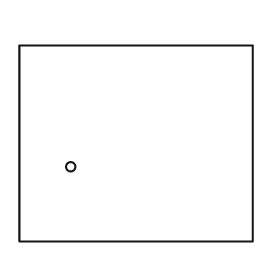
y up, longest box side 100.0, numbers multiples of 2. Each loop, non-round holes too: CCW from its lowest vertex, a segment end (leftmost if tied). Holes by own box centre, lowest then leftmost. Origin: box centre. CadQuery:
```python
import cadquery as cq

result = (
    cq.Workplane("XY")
    .moveTo(-50.0, -42.0)
    .lineTo(50.0, -42.0)
    .lineTo(50.0, 42.0)
    .lineTo(-50.0, 42.0)
    .close()
    .moveTo(-28.0, -10.0)
    .circle(2.0)
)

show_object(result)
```